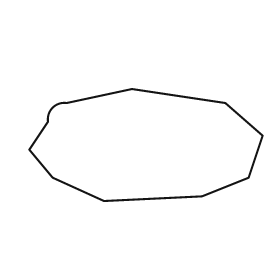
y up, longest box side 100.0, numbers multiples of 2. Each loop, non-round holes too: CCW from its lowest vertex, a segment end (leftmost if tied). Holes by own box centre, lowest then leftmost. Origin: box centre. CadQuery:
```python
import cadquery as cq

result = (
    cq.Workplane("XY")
    .moveTo(-18.0, -24.0)
    .lineTo(24.0, -22.0)
    .lineTo(44.0, -14.0)
    .lineTo(50.0, 4.0)
    .lineTo(34.0, 18.0)
    .lineTo(-6.0, 24.0)
    .lineTo(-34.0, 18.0)
    .threePointArc((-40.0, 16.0), (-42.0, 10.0))
    .lineTo(-50.0, -2.0)
    .lineTo(-40.0, -14.0)
    .close()
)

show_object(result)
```